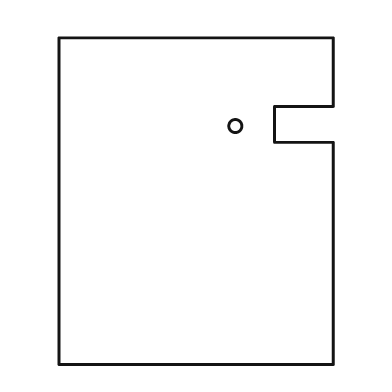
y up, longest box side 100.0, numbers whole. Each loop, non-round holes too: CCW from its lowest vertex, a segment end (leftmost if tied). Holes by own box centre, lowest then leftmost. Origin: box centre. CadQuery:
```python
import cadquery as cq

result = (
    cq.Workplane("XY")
    .moveTo(-42.0, -50.0)
    .lineTo(42.0, -50.0)
    .lineTo(42.0, 18.0)
    .lineTo(24.0, 18.0)
    .lineTo(24.0, 29.0)
    .lineTo(42.0, 29.0)
    .lineTo(42.0, 50.0)
    .lineTo(-42.0, 50.0)
    .close()
    .moveTo(12.0, 23.0)
    .circle(2.0)
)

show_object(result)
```